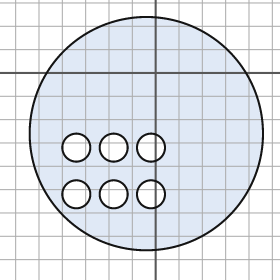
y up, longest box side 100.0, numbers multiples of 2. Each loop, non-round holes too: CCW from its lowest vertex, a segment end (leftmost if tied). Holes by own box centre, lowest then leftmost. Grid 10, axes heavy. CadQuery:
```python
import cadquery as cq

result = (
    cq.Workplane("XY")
    .moveTo(-4.0, -26.0)
    .circle(50.0)
    .moveTo(-34.0, -52.0)
    .circle(6.0)
    .moveTo(-18.0, -52.0)
    .circle(6.0)
    .moveTo(-2.0, -52.0)
    .circle(6.0)
    .moveTo(-34.0, -32.0)
    .circle(6.0)
    .moveTo(-18.0, -32.0)
    .circle(6.0)
    .moveTo(-2.0, -32.0)
    .circle(6.0)
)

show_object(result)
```